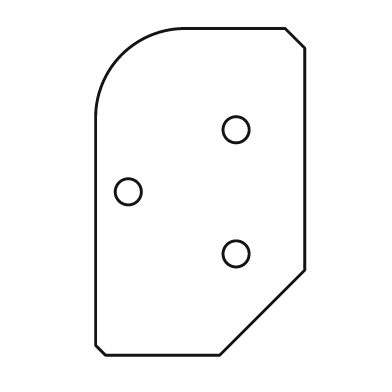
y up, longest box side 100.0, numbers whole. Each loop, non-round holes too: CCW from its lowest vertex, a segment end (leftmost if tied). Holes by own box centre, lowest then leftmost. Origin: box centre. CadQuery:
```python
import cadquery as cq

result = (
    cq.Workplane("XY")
    .moveTo(-29.0, -50.0)
    .lineTo(6.0, -50.0)
    .lineTo(32.0, -24.0)
    .lineTo(32.0, 44.0)
    .lineTo(26.0, 50.0)
    .lineTo(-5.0, 50.0)
    .threePointArc((-24.0, 42.0), (-32.0, 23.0))
    .lineTo(-32.0, -47.0)
    .close()
    .moveTo(11.0, -19.0)
    .circle(4.0)
    .moveTo(-22.0, 0.0)
    .circle(4.0)
    .moveTo(11.0, 19.0)
    .circle(4.0)
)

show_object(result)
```